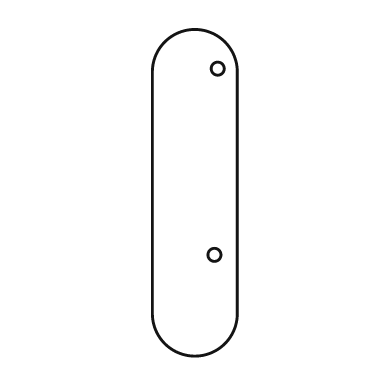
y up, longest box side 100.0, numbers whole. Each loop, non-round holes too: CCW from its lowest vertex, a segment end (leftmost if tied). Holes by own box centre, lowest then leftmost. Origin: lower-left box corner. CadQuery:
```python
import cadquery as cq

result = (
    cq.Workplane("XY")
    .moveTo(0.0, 13.0)
    .threePointArc((13.0, 0.0), (26.0, 13.0))
    .lineTo(26.0, 87.0)
    .threePointArc((13.0, 100.0), (0.0, 87.0))
    .close()
    .moveTo(19.0, 31.0)
    .circle(2.0)
    .moveTo(20.0, 88.0)
    .circle(2.0)
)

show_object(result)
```